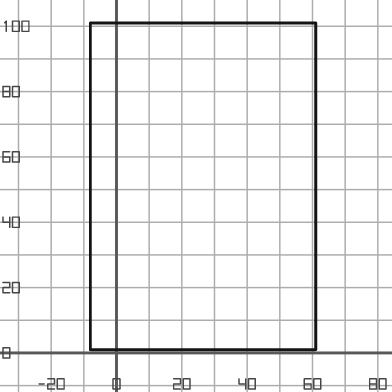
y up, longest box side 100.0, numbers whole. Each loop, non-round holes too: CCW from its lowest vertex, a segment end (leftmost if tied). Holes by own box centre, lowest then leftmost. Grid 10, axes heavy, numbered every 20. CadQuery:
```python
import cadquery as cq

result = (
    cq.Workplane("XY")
    .moveTo(-8.0, 1.0)
    .lineTo(61.0, 1.0)
    .lineTo(61.0, 101.0)
    .lineTo(-8.0, 101.0)
    .close()
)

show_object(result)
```